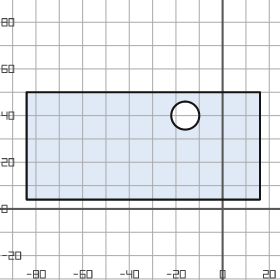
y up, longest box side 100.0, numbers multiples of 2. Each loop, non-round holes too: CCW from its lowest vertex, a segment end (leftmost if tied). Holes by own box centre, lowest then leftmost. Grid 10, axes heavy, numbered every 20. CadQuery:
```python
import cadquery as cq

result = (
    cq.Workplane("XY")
    .moveTo(-84.0, 4.0)
    .lineTo(16.0, 4.0)
    .lineTo(16.0, 50.0)
    .lineTo(-84.0, 50.0)
    .close()
    .moveTo(-16.0, 40.0)
    .circle(6.0)
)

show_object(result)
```